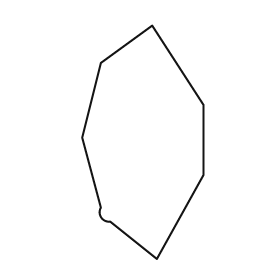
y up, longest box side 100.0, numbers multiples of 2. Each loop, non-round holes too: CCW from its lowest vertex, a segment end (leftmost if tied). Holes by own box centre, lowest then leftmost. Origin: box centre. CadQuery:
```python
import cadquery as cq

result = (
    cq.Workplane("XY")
    .moveTo(6.0, -50.0)
    .lineTo(26.0, -14.0)
    .lineTo(26.0, 16.0)
    .lineTo(4.0, 50.0)
    .lineTo(-18.0, 34.0)
    .lineTo(-26.0, 2.0)
    .lineTo(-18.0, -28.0)
    .threePointArc((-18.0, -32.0), (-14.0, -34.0))
    .close()
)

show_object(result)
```